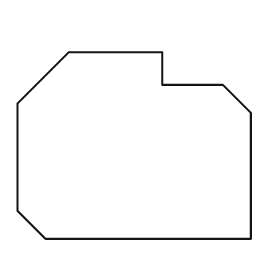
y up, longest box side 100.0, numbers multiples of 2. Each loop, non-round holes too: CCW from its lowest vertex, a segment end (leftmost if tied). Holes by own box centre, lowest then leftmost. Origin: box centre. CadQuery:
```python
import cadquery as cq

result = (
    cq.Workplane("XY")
    .moveTo(-38.0, -40.0)
    .lineTo(50.0, -40.0)
    .lineTo(50.0, 14.0)
    .lineTo(38.0, 26.0)
    .lineTo(12.0, 26.0)
    .lineTo(12.0, 40.0)
    .lineTo(-28.0, 40.0)
    .lineTo(-50.0, 18.0)
    .lineTo(-50.0, -28.0)
    .close()
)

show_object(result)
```